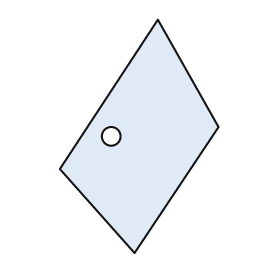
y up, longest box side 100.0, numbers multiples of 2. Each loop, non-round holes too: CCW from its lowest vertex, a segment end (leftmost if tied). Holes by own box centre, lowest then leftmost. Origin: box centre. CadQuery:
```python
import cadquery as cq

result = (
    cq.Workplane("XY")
    .moveTo(-2.0, -50.0)
    .lineTo(34.0, 4.0)
    .lineTo(8.0, 50.0)
    .lineTo(-34.0, -14.0)
    .close()
    .moveTo(-12.0, 0.0)
    .circle(4.0)
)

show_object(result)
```